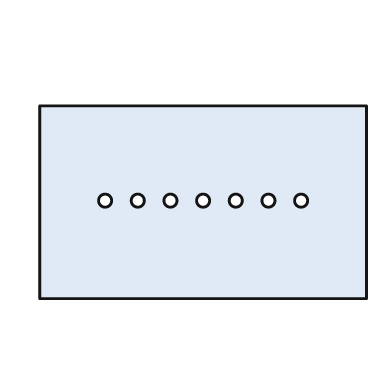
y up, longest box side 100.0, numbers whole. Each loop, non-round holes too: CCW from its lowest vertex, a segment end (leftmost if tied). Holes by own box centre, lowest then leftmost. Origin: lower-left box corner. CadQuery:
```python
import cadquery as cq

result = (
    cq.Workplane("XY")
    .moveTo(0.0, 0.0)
    .lineTo(100.0, 0.0)
    .lineTo(100.0, 59.0)
    .lineTo(0.0, 59.0)
    .close()
    .moveTo(20.0, 30.0)
    .circle(2.0)
    .moveTo(30.0, 30.0)
    .circle(2.0)
    .moveTo(40.0, 30.0)
    .circle(2.0)
    .moveTo(50.0, 30.0)
    .circle(2.0)
    .moveTo(60.0, 30.0)
    .circle(2.0)
    .moveTo(70.0, 30.0)
    .circle(2.0)
    .moveTo(80.0, 30.0)
    .circle(2.0)
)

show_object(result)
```